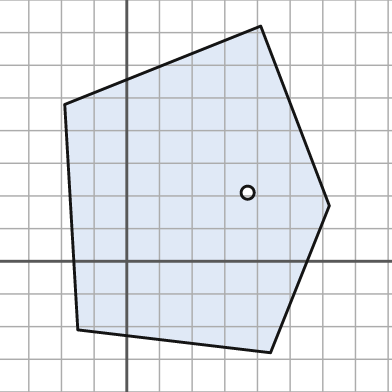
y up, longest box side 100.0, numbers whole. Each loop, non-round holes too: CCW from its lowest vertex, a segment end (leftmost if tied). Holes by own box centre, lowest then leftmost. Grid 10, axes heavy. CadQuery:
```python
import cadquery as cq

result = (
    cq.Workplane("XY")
    .moveTo(44.0, -28.0)
    .lineTo(62.0, 17.0)
    .lineTo(41.0, 72.0)
    .lineTo(-19.0, 48.0)
    .lineTo(-15.0, -21.0)
    .close()
    .moveTo(37.0, 21.0)
    .circle(2.0)
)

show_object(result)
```